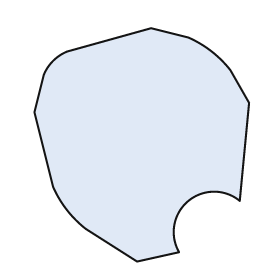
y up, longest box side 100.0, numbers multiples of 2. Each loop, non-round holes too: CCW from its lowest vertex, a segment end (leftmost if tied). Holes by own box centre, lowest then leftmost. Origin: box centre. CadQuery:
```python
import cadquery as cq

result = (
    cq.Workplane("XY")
    .moveTo(-2.0, -50.0)
    .lineTo(16.0, -46.0)
    .threePointArc((20.0, -24.0), (42.0, -24.0))
    .lineTo(46.0, 18.0)
    .lineTo(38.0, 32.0)
    .threePointArc((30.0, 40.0), (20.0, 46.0))
    .lineTo(4.0, 50.0)
    .lineTo(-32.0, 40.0)
    .threePointArc((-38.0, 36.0), (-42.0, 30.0))
    .lineTo(-46.0, 14.0)
    .lineTo(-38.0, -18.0)
    .threePointArc((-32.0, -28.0), (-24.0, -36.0))
    .close()
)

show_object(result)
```